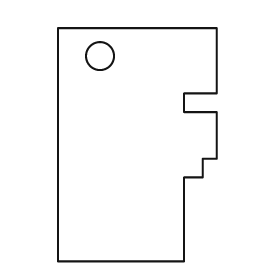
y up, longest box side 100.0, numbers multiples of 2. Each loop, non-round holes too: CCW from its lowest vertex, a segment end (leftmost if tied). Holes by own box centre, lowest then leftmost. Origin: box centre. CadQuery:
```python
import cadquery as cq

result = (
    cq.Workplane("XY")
    .moveTo(-34.0, -50.0)
    .lineTo(20.0, -50.0)
    .lineTo(20.0, -14.0)
    .lineTo(28.0, -14.0)
    .lineTo(28.0, -6.0)
    .lineTo(34.0, -6.0)
    .lineTo(34.0, 14.0)
    .lineTo(20.0, 14.0)
    .lineTo(20.0, 22.0)
    .lineTo(34.0, 22.0)
    .lineTo(34.0, 50.0)
    .lineTo(-34.0, 50.0)
    .close()
    .moveTo(-16.0, 38.0)
    .circle(6.0)
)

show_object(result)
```